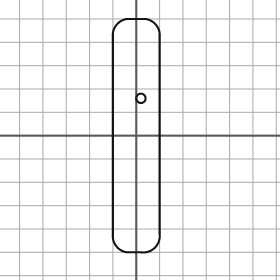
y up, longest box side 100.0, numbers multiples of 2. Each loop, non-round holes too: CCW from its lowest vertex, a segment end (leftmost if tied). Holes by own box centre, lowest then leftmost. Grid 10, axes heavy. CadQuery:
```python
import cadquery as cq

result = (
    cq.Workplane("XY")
    .moveTo(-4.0, -50.0)
    .lineTo(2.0, -50.0)
    .threePointArc((8.0, -48.0), (10.0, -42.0))
    .lineTo(10.0, 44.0)
    .threePointArc((8.0, 48.0), (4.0, 50.0))
    .lineTo(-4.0, 50.0)
    .threePointArc((-8.0, 48.0), (-10.0, 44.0))
    .lineTo(-10.0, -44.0)
    .threePointArc((-8.0, -48.0), (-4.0, -50.0))
    .close()
    .moveTo(2.0, 16.0)
    .circle(2.0)
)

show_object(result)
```